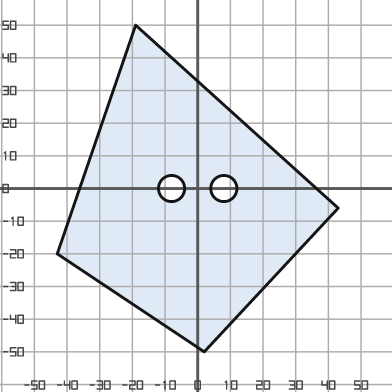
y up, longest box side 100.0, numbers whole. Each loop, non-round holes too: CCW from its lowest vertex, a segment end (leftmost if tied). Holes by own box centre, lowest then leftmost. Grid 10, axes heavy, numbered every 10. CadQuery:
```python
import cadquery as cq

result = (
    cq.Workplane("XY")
    .moveTo(2.0, -50.0)
    .lineTo(43.0, -6.0)
    .lineTo(-19.0, 50.0)
    .lineTo(-43.0, -20.0)
    .close()
    .moveTo(-8.0, 0.0)
    .circle(4.0)
    .moveTo(8.0, 0.0)
    .circle(4.0)
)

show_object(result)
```